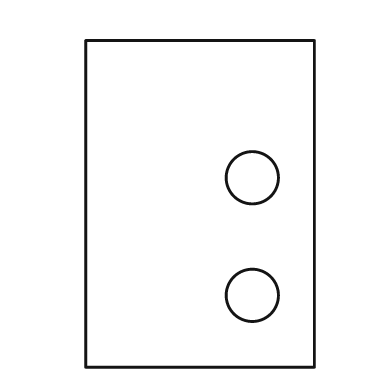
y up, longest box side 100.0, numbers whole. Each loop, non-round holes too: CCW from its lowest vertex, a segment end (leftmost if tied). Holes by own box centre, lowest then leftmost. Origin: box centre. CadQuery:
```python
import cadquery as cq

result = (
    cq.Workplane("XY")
    .moveTo(-35.0, -50.0)
    .lineTo(35.0, -50.0)
    .lineTo(35.0, 50.0)
    .lineTo(-35.0, 50.0)
    .close()
    .moveTo(16.0, -28.0)
    .circle(8.0)
    .moveTo(16.0, 8.0)
    .circle(8.0)
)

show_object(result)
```